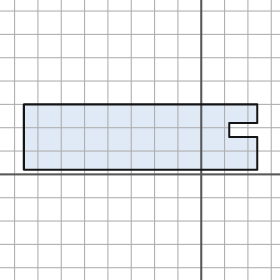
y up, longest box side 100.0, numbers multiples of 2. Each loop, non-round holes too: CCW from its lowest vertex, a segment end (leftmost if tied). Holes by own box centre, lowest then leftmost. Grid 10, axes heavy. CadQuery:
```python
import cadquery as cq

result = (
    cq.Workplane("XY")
    .moveTo(-76.0, 2.0)
    .lineTo(24.0, 2.0)
    .lineTo(24.0, 16.0)
    .lineTo(12.0, 16.0)
    .lineTo(12.0, 22.0)
    .lineTo(24.0, 22.0)
    .lineTo(24.0, 30.0)
    .lineTo(-76.0, 30.0)
    .close()
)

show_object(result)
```